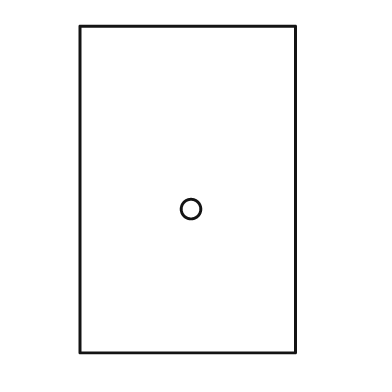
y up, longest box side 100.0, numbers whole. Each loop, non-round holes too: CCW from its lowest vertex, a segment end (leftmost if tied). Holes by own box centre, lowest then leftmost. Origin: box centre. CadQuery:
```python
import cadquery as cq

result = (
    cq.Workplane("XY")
    .moveTo(-33.0, -50.0)
    .lineTo(33.0, -50.0)
    .lineTo(33.0, 50.0)
    .lineTo(-33.0, 50.0)
    .close()
    .moveTo(1.0, -6.0)
    .circle(3.0)
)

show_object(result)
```